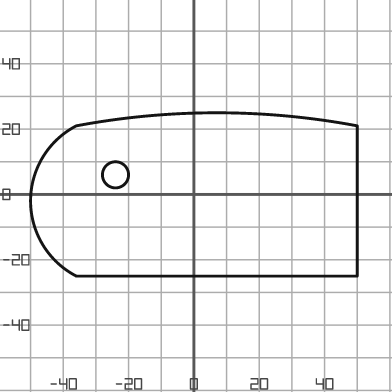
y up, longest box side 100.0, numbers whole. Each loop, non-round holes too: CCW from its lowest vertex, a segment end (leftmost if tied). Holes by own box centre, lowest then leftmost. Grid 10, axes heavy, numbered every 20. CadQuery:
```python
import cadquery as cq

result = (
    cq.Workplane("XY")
    .moveTo(-36.0, -25.0)
    .lineTo(50.0, -25.0)
    .lineTo(50.0, 21.0)
    .threePointArc((7.0, 25.0), (-36.0, 21.0))
    .threePointArc((-50.0, -2.0), (-36.0, -25.0))
    .close()
    .moveTo(-24.0, 6.0)
    .circle(4.0)
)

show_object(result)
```